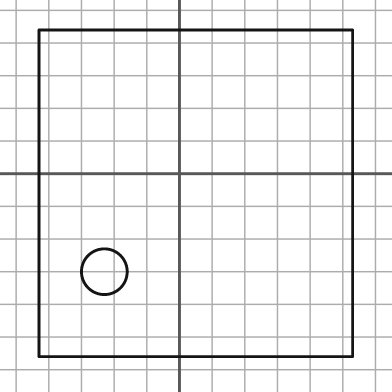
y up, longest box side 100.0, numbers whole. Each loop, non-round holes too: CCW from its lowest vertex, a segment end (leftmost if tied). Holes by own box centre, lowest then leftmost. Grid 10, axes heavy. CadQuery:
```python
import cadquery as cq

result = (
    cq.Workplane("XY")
    .moveTo(-43.0, -56.0)
    .lineTo(53.0, -56.0)
    .lineTo(53.0, 44.0)
    .lineTo(-43.0, 44.0)
    .close()
    .moveTo(-23.0, -30.0)
    .circle(7.0)
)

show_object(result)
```